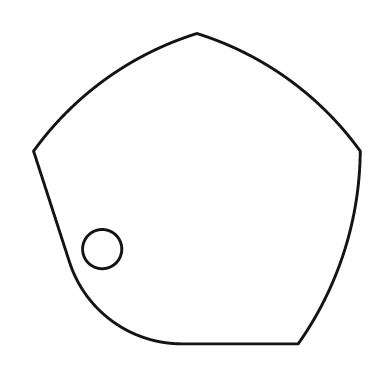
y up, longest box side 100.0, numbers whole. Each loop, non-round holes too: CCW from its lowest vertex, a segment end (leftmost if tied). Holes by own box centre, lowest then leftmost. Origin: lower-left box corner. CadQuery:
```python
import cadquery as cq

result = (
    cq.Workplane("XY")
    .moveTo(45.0, 0.0)
    .lineTo(81.0, 0.0)
    .threePointArc((95.0, 28.0), (100.0, 59.0))
    .threePointArc((78.0, 81.0), (50.0, 95.0))
    .threePointArc((22.0, 81.0), (0.0, 59.0))
    .lineTo(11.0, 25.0)
    .threePointArc((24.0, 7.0), (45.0, 0.0))
    .close()
    .moveTo(21.0, 29.0)
    .circle(6.0)
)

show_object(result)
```